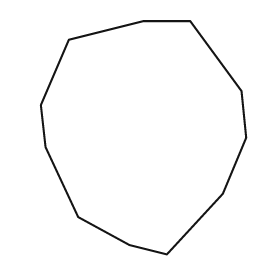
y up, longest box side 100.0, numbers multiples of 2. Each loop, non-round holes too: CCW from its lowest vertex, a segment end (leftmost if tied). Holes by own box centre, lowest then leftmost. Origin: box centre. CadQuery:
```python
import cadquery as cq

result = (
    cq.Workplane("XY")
    .moveTo(10.0, -50.0)
    .lineTo(34.0, -24.0)
    .lineTo(44.0, 0.0)
    .lineTo(42.0, 20.0)
    .lineTo(20.0, 50.0)
    .lineTo(0.0, 50.0)
    .lineTo(-32.0, 42.0)
    .lineTo(-44.0, 14.0)
    .lineTo(-42.0, -4.0)
    .lineTo(-28.0, -34.0)
    .lineTo(-6.0, -46.0)
    .close()
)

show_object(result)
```